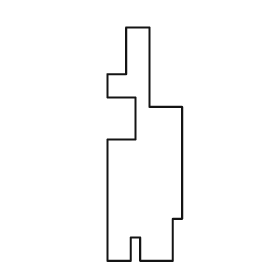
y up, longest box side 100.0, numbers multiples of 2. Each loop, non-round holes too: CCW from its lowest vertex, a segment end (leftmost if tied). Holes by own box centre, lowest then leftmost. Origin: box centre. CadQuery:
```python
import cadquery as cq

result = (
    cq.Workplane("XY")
    .moveTo(-16.0, -50.0)
    .lineTo(-6.0, -50.0)
    .lineTo(-6.0, -40.0)
    .lineTo(-2.0, -40.0)
    .lineTo(-2.0, -50.0)
    .lineTo(12.0, -50.0)
    .lineTo(12.0, -32.0)
    .lineTo(16.0, -32.0)
    .lineTo(16.0, 16.0)
    .lineTo(2.0, 16.0)
    .lineTo(2.0, 50.0)
    .lineTo(-8.0, 50.0)
    .lineTo(-8.0, 30.0)
    .lineTo(-16.0, 30.0)
    .lineTo(-16.0, 20.0)
    .lineTo(-4.0, 20.0)
    .lineTo(-4.0, 2.0)
    .lineTo(-16.0, 2.0)
    .close()
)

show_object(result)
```